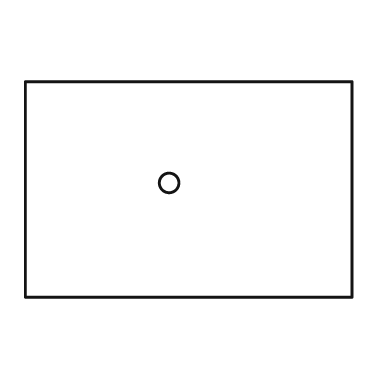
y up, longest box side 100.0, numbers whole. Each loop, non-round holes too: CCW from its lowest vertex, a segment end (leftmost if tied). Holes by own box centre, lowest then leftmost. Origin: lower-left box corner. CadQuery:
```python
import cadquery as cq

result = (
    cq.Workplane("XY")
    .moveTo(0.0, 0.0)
    .lineTo(100.0, 0.0)
    .lineTo(100.0, 66.0)
    .lineTo(0.0, 66.0)
    .close()
    .moveTo(44.0, 35.0)
    .circle(3.0)
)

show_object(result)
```